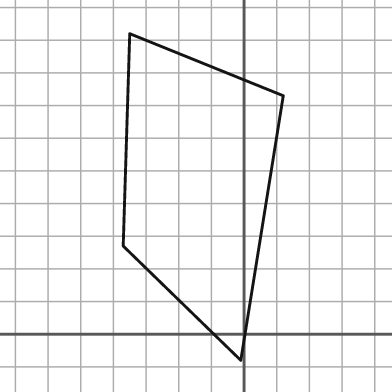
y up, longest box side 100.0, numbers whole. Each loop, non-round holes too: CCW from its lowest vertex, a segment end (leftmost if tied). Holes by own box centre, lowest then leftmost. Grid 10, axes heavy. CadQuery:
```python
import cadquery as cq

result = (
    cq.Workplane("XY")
    .moveTo(-1.0, -8.0)
    .lineTo(12.0, 73.0)
    .lineTo(-35.0, 92.0)
    .lineTo(-37.0, 27.0)
    .close()
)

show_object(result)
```